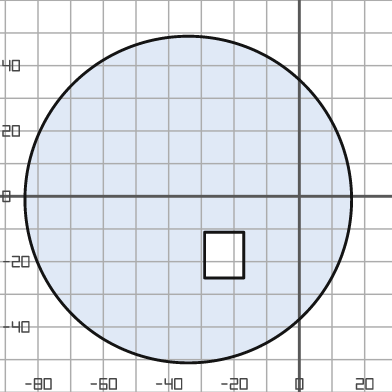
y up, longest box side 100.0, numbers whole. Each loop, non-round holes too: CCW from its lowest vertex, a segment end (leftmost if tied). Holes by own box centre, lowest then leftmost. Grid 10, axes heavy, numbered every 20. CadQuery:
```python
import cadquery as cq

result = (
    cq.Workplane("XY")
    .moveTo(-34.0, -1.0)
    .circle(50.0)
    .moveTo(-29.0, -25.0)
    .lineTo(-17.0, -25.0)
    .lineTo(-17.0, -11.0)
    .lineTo(-29.0, -11.0)
    .close()
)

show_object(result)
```